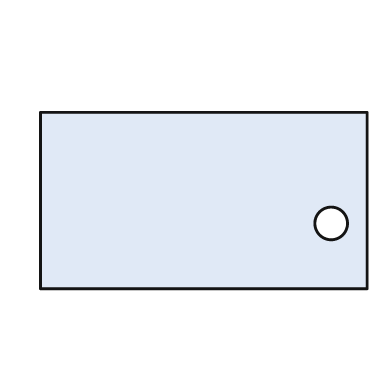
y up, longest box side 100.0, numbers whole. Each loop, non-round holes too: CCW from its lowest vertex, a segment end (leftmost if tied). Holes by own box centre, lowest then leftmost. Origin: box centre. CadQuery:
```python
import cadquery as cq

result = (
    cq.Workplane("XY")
    .moveTo(-50.0, -27.0)
    .lineTo(50.0, -27.0)
    .lineTo(50.0, 27.0)
    .lineTo(-50.0, 27.0)
    .close()
    .moveTo(39.0, -7.0)
    .circle(5.0)
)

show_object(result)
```